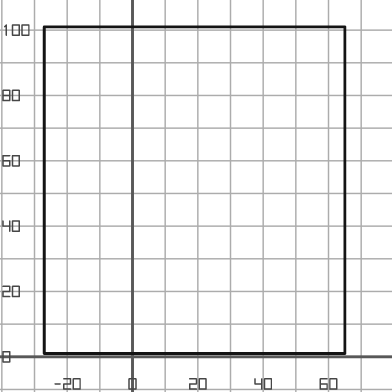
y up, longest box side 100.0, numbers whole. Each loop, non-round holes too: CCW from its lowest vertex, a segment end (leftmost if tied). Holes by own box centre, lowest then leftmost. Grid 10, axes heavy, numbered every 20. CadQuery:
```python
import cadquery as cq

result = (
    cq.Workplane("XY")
    .moveTo(-27.0, 1.0)
    .lineTo(65.0, 1.0)
    .lineTo(65.0, 101.0)
    .lineTo(-27.0, 101.0)
    .close()
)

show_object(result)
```